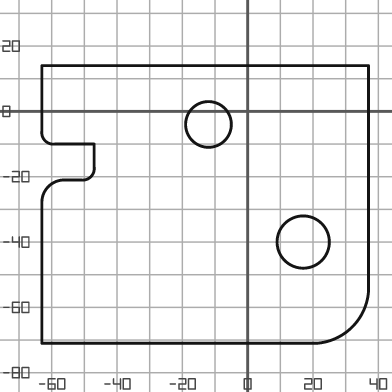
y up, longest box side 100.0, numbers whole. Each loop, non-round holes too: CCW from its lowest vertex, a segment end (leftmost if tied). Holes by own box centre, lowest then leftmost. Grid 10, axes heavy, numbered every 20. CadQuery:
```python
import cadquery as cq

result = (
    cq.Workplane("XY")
    .moveTo(-63.0, -71.0)
    .lineTo(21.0, -71.0)
    .threePointArc((32.0, -66.0), (37.0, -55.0))
    .lineTo(37.0, 14.0)
    .lineTo(-63.0, 14.0)
    .lineTo(-63.0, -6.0)
    .threePointArc((-62.0, -9.0), (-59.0, -10.0))
    .lineTo(-47.0, -10.0)
    .lineTo(-47.0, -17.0)
    .threePointArc((-48.0, -20.0), (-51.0, -21.0))
    .lineTo(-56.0, -21.0)
    .threePointArc((-61.0, -23.0), (-63.0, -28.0))
    .close()
    .moveTo(17.0, -40.0)
    .circle(8.0)
    .moveTo(-12.0, -4.0)
    .circle(7.0)
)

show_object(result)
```